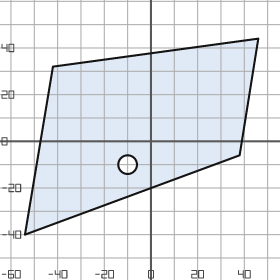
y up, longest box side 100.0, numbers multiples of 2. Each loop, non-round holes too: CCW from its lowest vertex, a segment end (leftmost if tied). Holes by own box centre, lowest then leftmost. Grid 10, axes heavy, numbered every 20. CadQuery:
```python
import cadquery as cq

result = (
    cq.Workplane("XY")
    .moveTo(-54.0, -40.0)
    .lineTo(38.0, -6.0)
    .lineTo(46.0, 44.0)
    .lineTo(-42.0, 32.0)
    .close()
    .moveTo(-10.0, -10.0)
    .circle(4.0)
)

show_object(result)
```